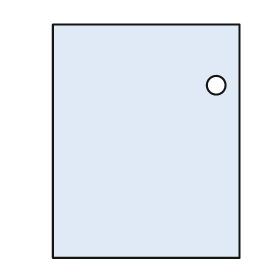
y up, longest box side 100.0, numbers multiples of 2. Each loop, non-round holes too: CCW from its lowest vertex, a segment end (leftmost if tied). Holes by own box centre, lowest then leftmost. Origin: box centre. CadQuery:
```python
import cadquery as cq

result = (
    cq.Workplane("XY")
    .moveTo(-40.0, -50.0)
    .lineTo(40.0, -50.0)
    .lineTo(40.0, 50.0)
    .lineTo(-40.0, 50.0)
    .close()
    .moveTo(30.0, 24.0)
    .circle(4.0)
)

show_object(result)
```